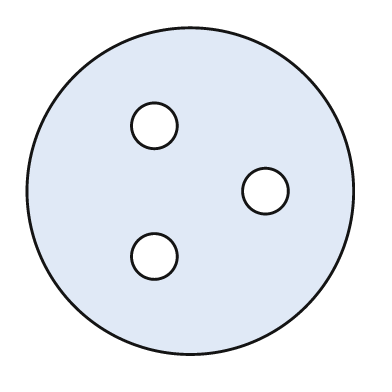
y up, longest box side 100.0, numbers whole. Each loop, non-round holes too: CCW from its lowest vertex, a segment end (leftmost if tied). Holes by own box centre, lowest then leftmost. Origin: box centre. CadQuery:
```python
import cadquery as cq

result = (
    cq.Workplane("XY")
    .moveTo(0.0, 0.0)
    .circle(50.0)
    .moveTo(-11.0, -20.0)
    .circle(7.0)
    .moveTo(23.0, 0.0)
    .circle(7.0)
    .moveTo(-11.0, 20.0)
    .circle(7.0)
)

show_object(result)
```